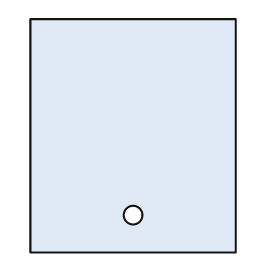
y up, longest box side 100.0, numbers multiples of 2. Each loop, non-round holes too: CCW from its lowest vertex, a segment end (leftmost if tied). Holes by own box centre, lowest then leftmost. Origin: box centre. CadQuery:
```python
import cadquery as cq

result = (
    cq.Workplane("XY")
    .moveTo(-44.0, -50.0)
    .lineTo(44.0, -50.0)
    .lineTo(44.0, 50.0)
    .lineTo(-44.0, 50.0)
    .close()
    .moveTo(0.0, -34.0)
    .circle(4.0)
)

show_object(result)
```